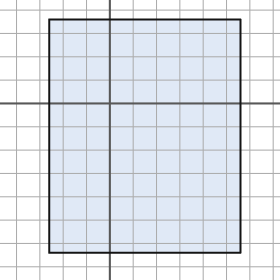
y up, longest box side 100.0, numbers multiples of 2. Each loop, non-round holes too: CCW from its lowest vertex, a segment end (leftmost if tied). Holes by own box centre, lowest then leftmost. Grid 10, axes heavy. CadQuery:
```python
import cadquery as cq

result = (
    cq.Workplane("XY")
    .moveTo(-26.0, -64.0)
    .lineTo(56.0, -64.0)
    .lineTo(56.0, 36.0)
    .lineTo(-26.0, 36.0)
    .close()
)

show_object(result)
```